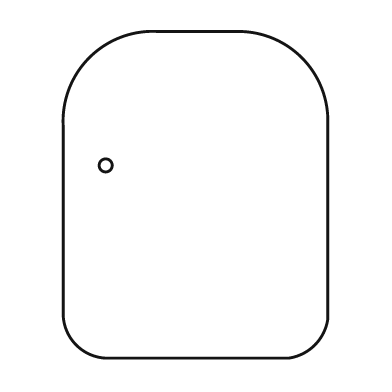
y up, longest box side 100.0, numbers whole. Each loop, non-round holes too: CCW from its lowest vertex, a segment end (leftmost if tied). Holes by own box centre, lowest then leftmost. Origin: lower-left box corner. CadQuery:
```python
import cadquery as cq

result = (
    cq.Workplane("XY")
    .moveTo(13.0, 0.0)
    .lineTo(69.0, 0.0)
    .threePointArc((77.0, 4.0), (81.0, 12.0))
    .lineTo(81.0, 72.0)
    .threePointArc((73.0, 92.0), (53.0, 100.0))
    .lineTo(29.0, 100.0)
    .threePointArc((8.0, 92.0), (0.0, 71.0))
    .lineTo(0.0, 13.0)
    .threePointArc((4.0, 4.0), (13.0, 0.0))
    .close()
    .moveTo(13.0, 59.0)
    .circle(2.0)
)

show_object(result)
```